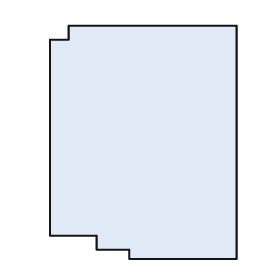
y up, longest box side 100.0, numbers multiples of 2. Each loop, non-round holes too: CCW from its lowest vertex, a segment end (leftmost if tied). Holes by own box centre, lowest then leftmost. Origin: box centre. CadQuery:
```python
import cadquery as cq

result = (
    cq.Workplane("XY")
    .moveTo(-6.0, -50.0)
    .lineTo(40.0, -50.0)
    .lineTo(40.0, 50.0)
    .lineTo(-32.0, 50.0)
    .lineTo(-32.0, 44.0)
    .lineTo(-40.0, 44.0)
    .lineTo(-40.0, -40.0)
    .lineTo(-20.0, -40.0)
    .lineTo(-20.0, -46.0)
    .lineTo(-6.0, -46.0)
    .close()
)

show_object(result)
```